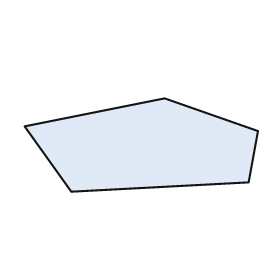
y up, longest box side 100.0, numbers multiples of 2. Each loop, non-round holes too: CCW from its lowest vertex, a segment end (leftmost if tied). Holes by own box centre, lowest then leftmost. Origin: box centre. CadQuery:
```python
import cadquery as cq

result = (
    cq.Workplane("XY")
    .moveTo(-30.0, -20.0)
    .lineTo(46.0, -16.0)
    .lineTo(50.0, 6.0)
    .lineTo(10.0, 20.0)
    .lineTo(-50.0, 8.0)
    .close()
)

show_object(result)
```